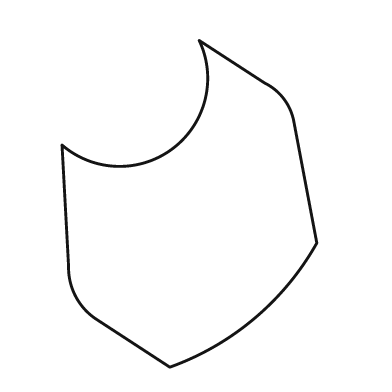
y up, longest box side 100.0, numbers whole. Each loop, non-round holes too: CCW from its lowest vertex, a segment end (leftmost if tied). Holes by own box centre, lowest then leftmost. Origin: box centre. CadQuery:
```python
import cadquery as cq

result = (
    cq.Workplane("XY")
    .moveTo(-6.0, -50.0)
    .threePointArc((20.0, -35.0), (39.0, -12.0))
    .lineTo(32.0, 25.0)
    .threePointArc((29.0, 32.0), (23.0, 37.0))
    .lineTo(3.0, 50.0)
    .threePointArc((-5.0, 17.0), (-39.0, 18.0))
    .lineTo(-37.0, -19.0)
    .threePointArc((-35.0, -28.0), (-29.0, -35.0))
    .close()
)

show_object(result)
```